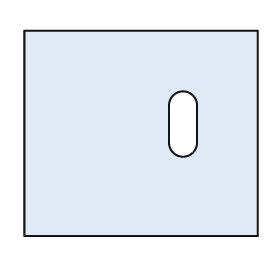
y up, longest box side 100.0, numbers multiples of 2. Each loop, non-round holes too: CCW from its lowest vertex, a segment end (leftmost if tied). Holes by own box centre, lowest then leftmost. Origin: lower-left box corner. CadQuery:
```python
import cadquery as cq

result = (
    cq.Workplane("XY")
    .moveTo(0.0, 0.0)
    .lineTo(100.0, 0.0)
    .lineTo(100.0, 88.0)
    .lineTo(0.0, 88.0)
    .close()
    .moveTo(62.0, 40.0)
    .threePointArc((68.0, 34.0), (74.0, 40.0))
    .lineTo(74.0, 56.0)
    .threePointArc((68.0, 62.0), (62.0, 56.0))
    .close()
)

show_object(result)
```